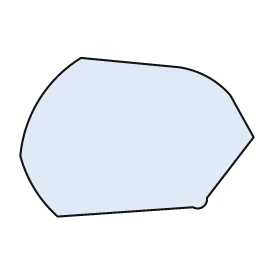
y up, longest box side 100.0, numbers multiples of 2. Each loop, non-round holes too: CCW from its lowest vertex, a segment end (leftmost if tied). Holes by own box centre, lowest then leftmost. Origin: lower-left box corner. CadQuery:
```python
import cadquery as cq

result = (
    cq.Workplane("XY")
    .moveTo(16.0, 0.0)
    .lineTo(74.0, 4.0)
    .threePointArc((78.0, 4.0), (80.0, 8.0))
    .lineTo(100.0, 34.0)
    .lineTo(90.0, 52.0)
    .threePointArc((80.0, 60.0), (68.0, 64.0))
    .lineTo(26.0, 68.0)
    .threePointArc((8.0, 50.0), (0.0, 26.0))
    .threePointArc((6.0, 12.0), (16.0, 0.0))
    .close()
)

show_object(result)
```